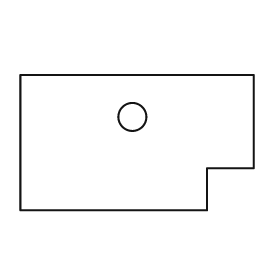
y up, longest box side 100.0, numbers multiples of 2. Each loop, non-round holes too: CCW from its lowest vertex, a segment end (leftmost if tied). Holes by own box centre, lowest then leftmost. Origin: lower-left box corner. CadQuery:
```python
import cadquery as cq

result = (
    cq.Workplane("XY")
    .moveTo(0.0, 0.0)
    .lineTo(80.0, 0.0)
    .lineTo(80.0, 18.0)
    .lineTo(100.0, 18.0)
    .lineTo(100.0, 58.0)
    .lineTo(0.0, 58.0)
    .close()
    .moveTo(48.0, 40.0)
    .circle(6.0)
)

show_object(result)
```